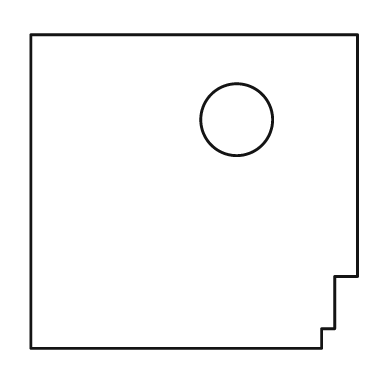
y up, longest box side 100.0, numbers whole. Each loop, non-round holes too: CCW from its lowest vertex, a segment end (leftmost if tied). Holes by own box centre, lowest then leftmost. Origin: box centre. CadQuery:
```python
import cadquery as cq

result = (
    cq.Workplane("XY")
    .moveTo(-50.0, -48.0)
    .lineTo(39.0, -48.0)
    .lineTo(39.0, -42.0)
    .lineTo(43.0, -42.0)
    .lineTo(43.0, -26.0)
    .lineTo(50.0, -26.0)
    .lineTo(50.0, 48.0)
    .lineTo(-50.0, 48.0)
    .close()
    .moveTo(13.0, 22.0)
    .circle(11.0)
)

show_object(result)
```